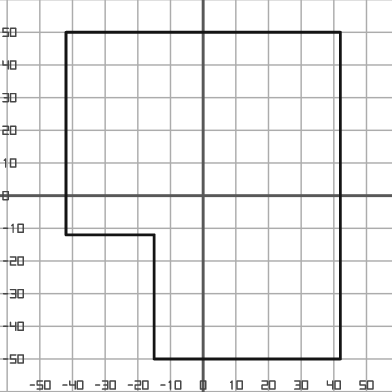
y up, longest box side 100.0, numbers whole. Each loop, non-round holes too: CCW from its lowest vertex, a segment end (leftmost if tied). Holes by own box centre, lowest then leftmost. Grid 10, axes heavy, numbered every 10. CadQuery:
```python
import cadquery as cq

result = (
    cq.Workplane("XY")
    .moveTo(-15.0, -50.0)
    .lineTo(42.0, -50.0)
    .lineTo(42.0, 50.0)
    .lineTo(-42.0, 50.0)
    .lineTo(-42.0, -12.0)
    .lineTo(-15.0, -12.0)
    .close()
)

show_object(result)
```